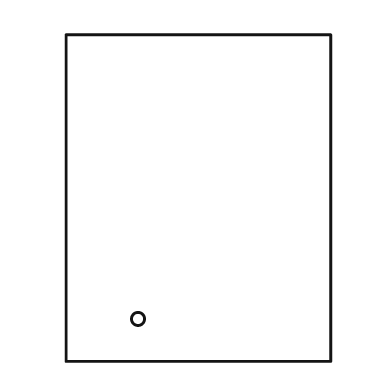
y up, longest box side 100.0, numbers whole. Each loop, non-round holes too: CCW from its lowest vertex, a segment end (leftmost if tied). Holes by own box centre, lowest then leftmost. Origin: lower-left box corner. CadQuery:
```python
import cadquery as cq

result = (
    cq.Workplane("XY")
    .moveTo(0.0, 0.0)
    .lineTo(81.0, 0.0)
    .lineTo(81.0, 100.0)
    .lineTo(0.0, 100.0)
    .close()
    .moveTo(22.0, 13.0)
    .circle(2.0)
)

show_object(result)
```